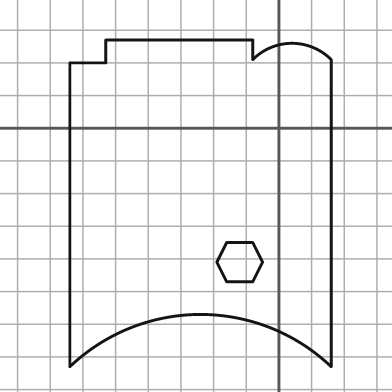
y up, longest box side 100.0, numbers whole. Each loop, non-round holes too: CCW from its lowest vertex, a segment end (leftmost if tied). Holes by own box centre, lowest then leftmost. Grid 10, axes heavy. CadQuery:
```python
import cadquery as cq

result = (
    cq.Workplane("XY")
    .moveTo(-64.0, -73.0)
    .threePointArc((-24.0, -57.0), (16.0, -73.0))
    .lineTo(16.0, 21.0)
    .threePointArc((4.0, 26.0), (-8.0, 21.0))
    .lineTo(-8.0, 27.0)
    .lineTo(-53.0, 27.0)
    .lineTo(-53.0, 20.0)
    .lineTo(-64.0, 20.0)
    .close()
    .moveTo(-16.0, -47.0)
    .lineTo(-8.0, -47.0)
    .lineTo(-5.0, -41.0)
    .lineTo(-8.0, -35.0)
    .lineTo(-16.0, -35.0)
    .lineTo(-19.0, -41.0)
    .close()
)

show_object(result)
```